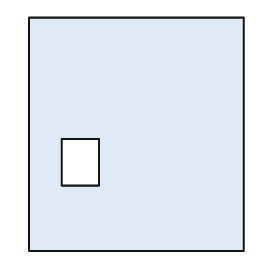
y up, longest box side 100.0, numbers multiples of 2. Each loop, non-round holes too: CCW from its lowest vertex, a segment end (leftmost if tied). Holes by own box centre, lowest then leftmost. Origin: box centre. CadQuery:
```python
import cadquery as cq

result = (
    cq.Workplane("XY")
    .moveTo(-46.0, -50.0)
    .lineTo(46.0, -50.0)
    .lineTo(46.0, 50.0)
    .lineTo(-46.0, 50.0)
    .close()
    .moveTo(-32.0, -22.0)
    .lineTo(-16.0, -22.0)
    .lineTo(-16.0, -2.0)
    .lineTo(-32.0, -2.0)
    .close()
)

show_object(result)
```